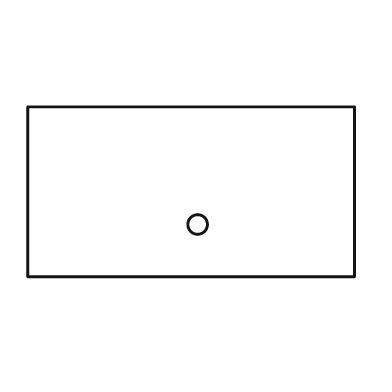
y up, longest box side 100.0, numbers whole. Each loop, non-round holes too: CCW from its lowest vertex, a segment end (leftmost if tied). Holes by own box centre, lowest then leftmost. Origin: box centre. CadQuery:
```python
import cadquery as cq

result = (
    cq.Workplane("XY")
    .moveTo(-50.0, -26.0)
    .lineTo(50.0, -26.0)
    .lineTo(50.0, 26.0)
    .lineTo(-50.0, 26.0)
    .close()
    .moveTo(2.0, -10.0)
    .circle(3.0)
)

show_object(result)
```